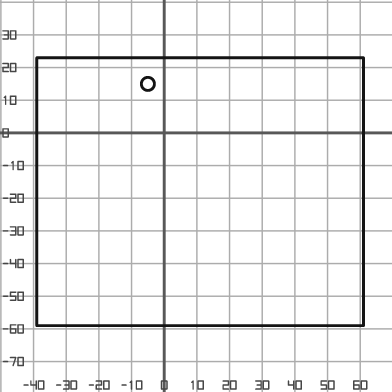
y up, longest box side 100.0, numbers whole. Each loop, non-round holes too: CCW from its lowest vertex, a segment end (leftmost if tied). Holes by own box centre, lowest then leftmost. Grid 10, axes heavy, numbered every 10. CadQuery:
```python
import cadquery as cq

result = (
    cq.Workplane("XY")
    .moveTo(-39.0, -59.0)
    .lineTo(61.0, -59.0)
    .lineTo(61.0, 23.0)
    .lineTo(-39.0, 23.0)
    .close()
    .moveTo(-5.0, 15.0)
    .circle(2.0)
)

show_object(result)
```